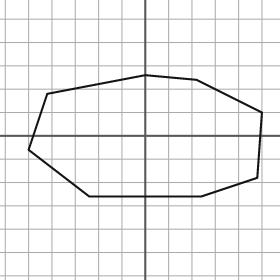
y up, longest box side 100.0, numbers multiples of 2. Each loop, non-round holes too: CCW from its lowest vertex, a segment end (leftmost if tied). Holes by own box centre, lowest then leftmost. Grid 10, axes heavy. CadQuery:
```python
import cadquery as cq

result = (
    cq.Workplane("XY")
    .moveTo(-24.0, -26.0)
    .lineTo(24.0, -26.0)
    .lineTo(48.0, -18.0)
    .lineTo(50.0, 10.0)
    .lineTo(22.0, 24.0)
    .lineTo(0.0, 26.0)
    .lineTo(-42.0, 18.0)
    .lineTo(-50.0, -6.0)
    .close()
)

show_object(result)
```